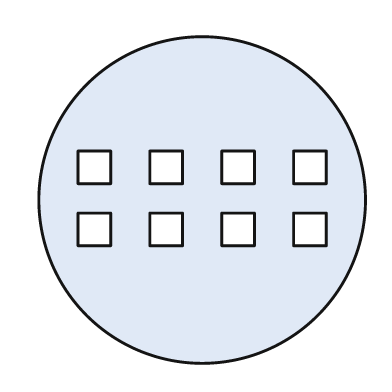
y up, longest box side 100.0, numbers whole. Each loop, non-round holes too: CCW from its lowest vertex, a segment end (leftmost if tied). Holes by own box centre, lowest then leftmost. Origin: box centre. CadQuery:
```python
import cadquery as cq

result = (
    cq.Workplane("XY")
    .moveTo(0.0, 0.0)
    .circle(50.0)
    .moveTo(-38.0, -14.0)
    .lineTo(-28.0, -14.0)
    .lineTo(-28.0, -4.0)
    .lineTo(-38.0, -4.0)
    .close()
    .moveTo(-16.0, -14.0)
    .lineTo(-6.0, -14.0)
    .lineTo(-6.0, -4.0)
    .lineTo(-16.0, -4.0)
    .close()
    .moveTo(6.0, -14.0)
    .lineTo(16.0, -14.0)
    .lineTo(16.0, -4.0)
    .lineTo(6.0, -4.0)
    .close()
    .moveTo(28.0, -14.0)
    .lineTo(38.0, -14.0)
    .lineTo(38.0, -4.0)
    .lineTo(28.0, -4.0)
    .close()
    .moveTo(-38.0, 5.0)
    .lineTo(-28.0, 5.0)
    .lineTo(-28.0, 15.0)
    .lineTo(-38.0, 15.0)
    .close()
    .moveTo(-16.0, 5.0)
    .lineTo(-6.0, 5.0)
    .lineTo(-6.0, 15.0)
    .lineTo(-16.0, 15.0)
    .close()
    .moveTo(6.0, 5.0)
    .lineTo(16.0, 5.0)
    .lineTo(16.0, 15.0)
    .lineTo(6.0, 15.0)
    .close()
    .moveTo(28.0, 5.0)
    .lineTo(38.0, 5.0)
    .lineTo(38.0, 15.0)
    .lineTo(28.0, 15.0)
    .close()
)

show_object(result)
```